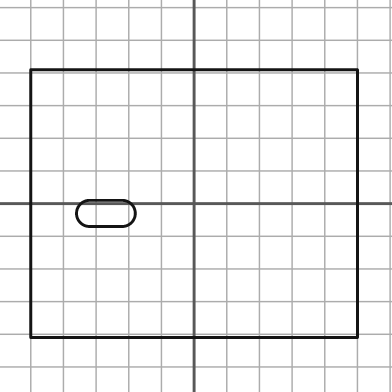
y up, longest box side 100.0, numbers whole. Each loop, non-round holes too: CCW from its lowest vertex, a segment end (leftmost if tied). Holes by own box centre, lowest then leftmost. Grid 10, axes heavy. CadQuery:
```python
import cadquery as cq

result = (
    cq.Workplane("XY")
    .moveTo(-50.0, -41.0)
    .lineTo(50.0, -41.0)
    .lineTo(50.0, 41.0)
    .lineTo(-50.0, 41.0)
    .close()
    .moveTo(-32.0, -7.0)
    .lineTo(-22.0, -7.0)
    .threePointArc((-18.0, -3.0), (-22.0, 1.0))
    .lineTo(-32.0, 1.0)
    .threePointArc((-36.0, -3.0), (-32.0, -7.0))
    .close()
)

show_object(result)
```